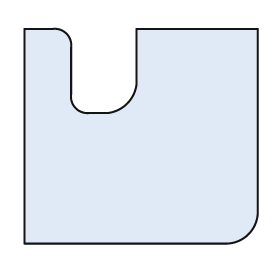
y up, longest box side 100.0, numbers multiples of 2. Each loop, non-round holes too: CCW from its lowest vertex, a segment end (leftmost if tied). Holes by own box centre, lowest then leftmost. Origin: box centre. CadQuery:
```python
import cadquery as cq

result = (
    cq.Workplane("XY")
    .moveTo(-50.0, -46.0)
    .lineTo(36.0, -46.0)
    .threePointArc((46.0, -42.0), (50.0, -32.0))
    .lineTo(50.0, 46.0)
    .lineTo(-2.0, 46.0)
    .lineTo(-2.0, 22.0)
    .threePointArc((-6.0, 14.0), (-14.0, 10.0))
    .lineTo(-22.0, 10.0)
    .threePointArc((-28.0, 12.0), (-30.0, 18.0))
    .lineTo(-30.0, 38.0)
    .threePointArc((-32.0, 44.0), (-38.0, 46.0))
    .lineTo(-50.0, 46.0)
    .close()
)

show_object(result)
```